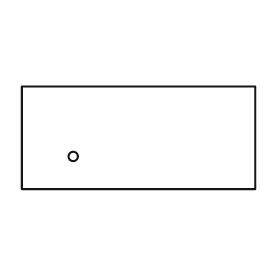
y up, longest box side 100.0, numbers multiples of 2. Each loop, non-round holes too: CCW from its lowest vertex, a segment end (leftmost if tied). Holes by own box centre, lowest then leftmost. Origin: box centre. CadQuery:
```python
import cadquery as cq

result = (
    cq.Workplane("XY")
    .moveTo(-50.0, -22.0)
    .lineTo(50.0, -22.0)
    .lineTo(50.0, 22.0)
    .lineTo(-50.0, 22.0)
    .close()
    .moveTo(-28.0, -8.0)
    .circle(2.0)
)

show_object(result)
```